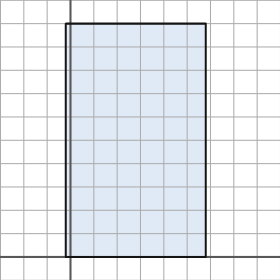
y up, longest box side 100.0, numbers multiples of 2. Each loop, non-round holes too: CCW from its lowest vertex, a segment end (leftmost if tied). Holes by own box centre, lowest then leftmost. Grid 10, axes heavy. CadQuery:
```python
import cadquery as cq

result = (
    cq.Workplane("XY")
    .moveTo(-2.0, 0.0)
    .lineTo(58.0, 0.0)
    .lineTo(58.0, 100.0)
    .lineTo(-2.0, 100.0)
    .close()
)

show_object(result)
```